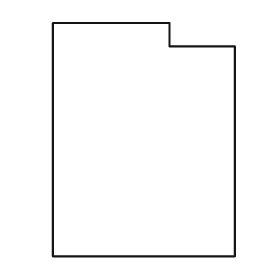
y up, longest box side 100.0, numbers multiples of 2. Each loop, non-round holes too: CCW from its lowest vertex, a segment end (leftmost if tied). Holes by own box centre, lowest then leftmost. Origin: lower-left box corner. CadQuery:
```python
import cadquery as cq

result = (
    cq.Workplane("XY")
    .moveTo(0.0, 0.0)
    .lineTo(78.0, 0.0)
    .lineTo(78.0, 90.0)
    .lineTo(50.0, 90.0)
    .lineTo(50.0, 100.0)
    .lineTo(0.0, 100.0)
    .close()
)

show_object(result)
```